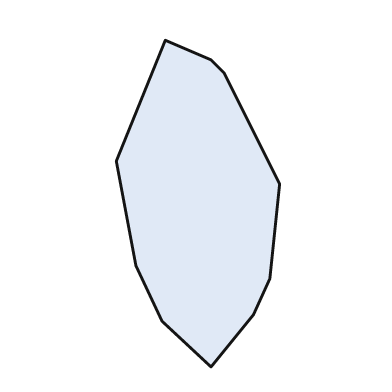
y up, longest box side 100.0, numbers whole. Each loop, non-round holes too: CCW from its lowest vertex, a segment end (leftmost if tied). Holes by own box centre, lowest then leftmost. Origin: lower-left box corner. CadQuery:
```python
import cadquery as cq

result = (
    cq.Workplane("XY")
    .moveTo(29.0, 0.0)
    .lineTo(42.0, 16.0)
    .lineTo(47.0, 27.0)
    .lineTo(50.0, 56.0)
    .lineTo(33.0, 90.0)
    .lineTo(29.0, 94.0)
    .lineTo(15.0, 100.0)
    .lineTo(0.0, 63.0)
    .lineTo(6.0, 31.0)
    .lineTo(14.0, 14.0)
    .close()
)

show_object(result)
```